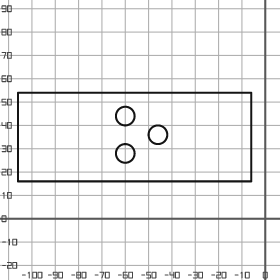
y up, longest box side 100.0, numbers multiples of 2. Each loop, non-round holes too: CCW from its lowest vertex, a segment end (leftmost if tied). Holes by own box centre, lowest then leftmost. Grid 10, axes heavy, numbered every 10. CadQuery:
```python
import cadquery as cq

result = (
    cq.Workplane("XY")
    .moveTo(-106.0, 16.0)
    .lineTo(-6.0, 16.0)
    .lineTo(-6.0, 54.0)
    .lineTo(-106.0, 54.0)
    .close()
    .moveTo(-60.0, 28.0)
    .circle(4.0)
    .moveTo(-46.0, 36.0)
    .circle(4.0)
    .moveTo(-60.0, 44.0)
    .circle(4.0)
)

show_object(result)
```